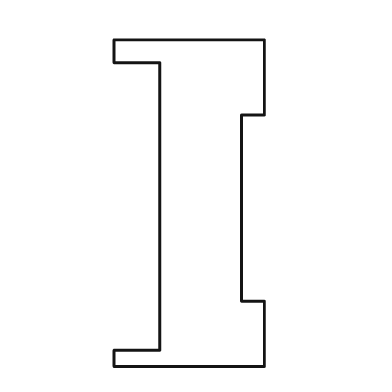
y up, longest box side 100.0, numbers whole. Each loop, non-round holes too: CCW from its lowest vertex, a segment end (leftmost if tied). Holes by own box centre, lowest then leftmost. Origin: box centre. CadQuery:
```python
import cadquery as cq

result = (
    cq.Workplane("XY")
    .moveTo(-23.0, -50.0)
    .lineTo(23.0, -50.0)
    .lineTo(23.0, -30.0)
    .lineTo(16.0, -30.0)
    .lineTo(16.0, 27.0)
    .lineTo(23.0, 27.0)
    .lineTo(23.0, 50.0)
    .lineTo(-23.0, 50.0)
    .lineTo(-23.0, 43.0)
    .lineTo(-9.0, 43.0)
    .lineTo(-9.0, -45.0)
    .lineTo(-23.0, -45.0)
    .close()
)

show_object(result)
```